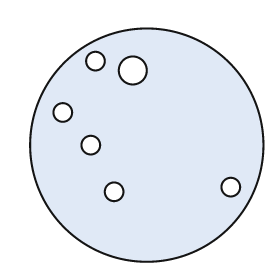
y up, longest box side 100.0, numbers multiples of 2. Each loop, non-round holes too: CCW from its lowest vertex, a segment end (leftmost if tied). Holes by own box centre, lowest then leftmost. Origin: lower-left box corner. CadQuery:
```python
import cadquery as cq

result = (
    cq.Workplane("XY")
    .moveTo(50.0, 50.0)
    .circle(50.0)
    .moveTo(36.0, 30.0)
    .circle(4.0)
    .moveTo(86.0, 32.0)
    .circle(4.0)
    .moveTo(26.0, 50.0)
    .circle(4.0)
    .moveTo(14.0, 64.0)
    .circle(4.0)
    .moveTo(44.0, 82.0)
    .circle(6.0)
    .moveTo(28.0, 86.0)
    .circle(4.0)
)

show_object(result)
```